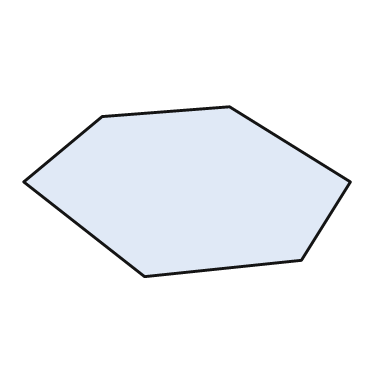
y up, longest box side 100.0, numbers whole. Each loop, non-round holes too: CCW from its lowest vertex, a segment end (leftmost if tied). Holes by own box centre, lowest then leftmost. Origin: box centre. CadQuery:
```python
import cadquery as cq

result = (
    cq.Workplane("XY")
    .moveTo(-13.0, -26.0)
    .lineTo(35.0, -21.0)
    .lineTo(50.0, 3.0)
    .lineTo(13.0, 26.0)
    .lineTo(-26.0, 23.0)
    .lineTo(-50.0, 3.0)
    .close()
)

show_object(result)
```